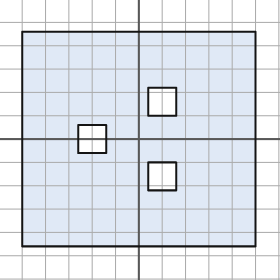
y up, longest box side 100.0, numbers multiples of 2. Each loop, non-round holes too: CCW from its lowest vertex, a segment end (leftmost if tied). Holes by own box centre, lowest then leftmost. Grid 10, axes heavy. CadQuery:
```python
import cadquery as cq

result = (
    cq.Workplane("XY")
    .moveTo(-50.0, -46.0)
    .lineTo(50.0, -46.0)
    .lineTo(50.0, 46.0)
    .lineTo(-50.0, 46.0)
    .close()
    .moveTo(4.0, -22.0)
    .lineTo(16.0, -22.0)
    .lineTo(16.0, -10.0)
    .lineTo(4.0, -10.0)
    .close()
    .moveTo(-26.0, -6.0)
    .lineTo(-14.0, -6.0)
    .lineTo(-14.0, 6.0)
    .lineTo(-26.0, 6.0)
    .close()
    .moveTo(4.0, 10.0)
    .lineTo(16.0, 10.0)
    .lineTo(16.0, 22.0)
    .lineTo(4.0, 22.0)
    .close()
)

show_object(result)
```